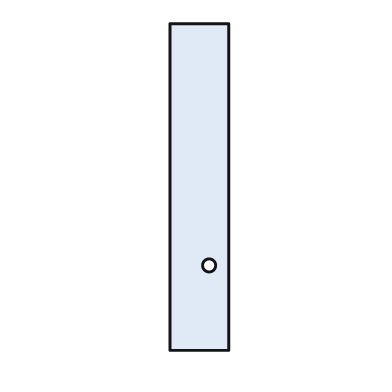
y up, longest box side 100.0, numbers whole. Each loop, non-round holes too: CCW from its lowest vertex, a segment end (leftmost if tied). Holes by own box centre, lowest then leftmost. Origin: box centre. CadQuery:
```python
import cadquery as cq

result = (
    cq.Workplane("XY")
    .moveTo(-9.0, -50.0)
    .lineTo(9.0, -50.0)
    .lineTo(9.0, 50.0)
    .lineTo(-9.0, 50.0)
    .close()
    .moveTo(3.0, -24.0)
    .circle(2.0)
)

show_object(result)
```